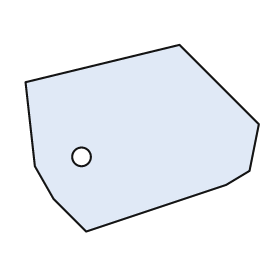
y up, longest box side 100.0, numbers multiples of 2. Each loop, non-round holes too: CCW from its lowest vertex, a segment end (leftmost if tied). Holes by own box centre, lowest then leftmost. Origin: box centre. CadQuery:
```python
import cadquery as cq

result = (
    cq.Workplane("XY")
    .moveTo(-24.0, -40.0)
    .lineTo(36.0, -20.0)
    .lineTo(46.0, -14.0)
    .lineTo(50.0, 6.0)
    .lineTo(16.0, 40.0)
    .lineTo(-50.0, 24.0)
    .lineTo(-46.0, -12.0)
    .lineTo(-38.0, -26.0)
    .close()
    .moveTo(-26.0, -8.0)
    .circle(4.0)
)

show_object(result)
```